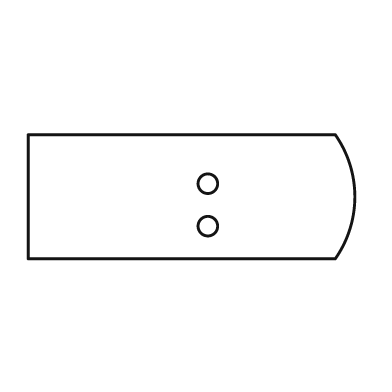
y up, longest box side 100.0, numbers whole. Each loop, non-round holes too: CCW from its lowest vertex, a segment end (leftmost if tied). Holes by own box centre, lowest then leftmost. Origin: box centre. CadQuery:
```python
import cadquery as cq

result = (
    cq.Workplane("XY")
    .moveTo(-50.0, -19.0)
    .lineTo(44.0, -19.0)
    .threePointArc((50.0, 0.0), (44.0, 19.0))
    .lineTo(-50.0, 19.0)
    .close()
    .moveTo(5.0, -9.0)
    .circle(3.0)
    .moveTo(5.0, 4.0)
    .circle(3.0)
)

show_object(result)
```